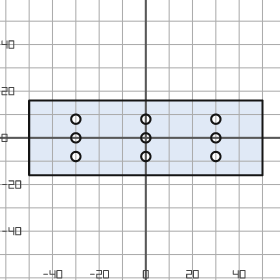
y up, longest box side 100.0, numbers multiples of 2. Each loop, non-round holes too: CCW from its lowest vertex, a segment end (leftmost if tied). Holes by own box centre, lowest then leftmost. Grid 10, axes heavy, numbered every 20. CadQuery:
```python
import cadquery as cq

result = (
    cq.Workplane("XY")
    .moveTo(-50.0, -16.0)
    .lineTo(50.0, -16.0)
    .lineTo(50.0, 16.0)
    .lineTo(-50.0, 16.0)
    .close()
    .moveTo(-30.0, -8.0)
    .circle(2.0)
    .moveTo(0.0, -8.0)
    .circle(2.0)
    .moveTo(30.0, -8.0)
    .circle(2.0)
    .moveTo(-30.0, 0.0)
    .circle(2.0)
    .moveTo(0.0, 0.0)
    .circle(2.0)
    .moveTo(30.0, 0.0)
    .circle(2.0)
    .moveTo(-30.0, 8.0)
    .circle(2.0)
    .moveTo(0.0, 8.0)
    .circle(2.0)
    .moveTo(30.0, 8.0)
    .circle(2.0)
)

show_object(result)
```